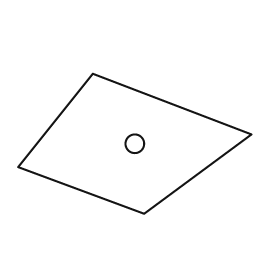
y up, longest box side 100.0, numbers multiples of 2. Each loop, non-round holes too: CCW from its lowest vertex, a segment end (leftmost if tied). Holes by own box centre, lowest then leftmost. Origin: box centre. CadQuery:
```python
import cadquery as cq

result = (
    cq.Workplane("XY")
    .moveTo(4.0, -30.0)
    .lineTo(50.0, 4.0)
    .lineTo(-18.0, 30.0)
    .lineTo(-50.0, -10.0)
    .close()
    .moveTo(0.0, 0.0)
    .circle(4.0)
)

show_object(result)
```